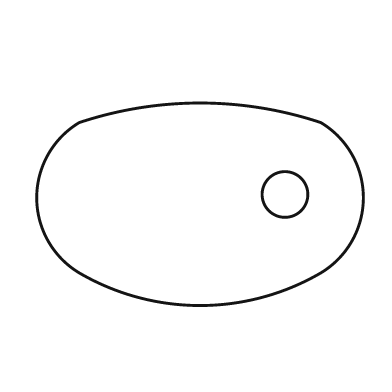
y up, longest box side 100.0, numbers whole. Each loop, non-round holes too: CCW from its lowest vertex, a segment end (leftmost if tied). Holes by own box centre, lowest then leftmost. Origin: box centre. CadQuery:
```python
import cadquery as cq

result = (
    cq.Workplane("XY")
    .moveTo(-37.0, -21.0)
    .threePointArc((0.0, -31.0), (37.0, -21.0))
    .threePointArc((50.0, 2.0), (37.0, 25.0))
    .threePointArc((0.0, 31.0), (-37.0, 25.0))
    .threePointArc((-50.0, 2.0), (-37.0, -21.0))
    .close()
    .moveTo(26.0, 3.0)
    .circle(7.0)
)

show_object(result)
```